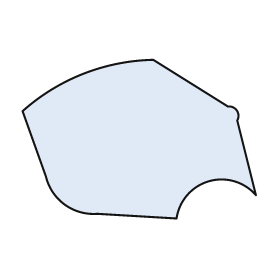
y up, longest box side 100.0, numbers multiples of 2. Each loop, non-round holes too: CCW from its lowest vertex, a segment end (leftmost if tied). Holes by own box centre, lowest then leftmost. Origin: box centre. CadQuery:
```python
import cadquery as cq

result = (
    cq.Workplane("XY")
    .moveTo(16.0, -34.0)
    .threePointArc((30.0, -18.0), (50.0, -24.0))
    .lineTo(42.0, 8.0)
    .threePointArc((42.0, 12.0), (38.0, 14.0))
    .lineTo(6.0, 34.0)
    .threePointArc((-24.0, 28.0), (-50.0, 12.0))
    .lineTo(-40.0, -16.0)
    .threePointArc((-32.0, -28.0), (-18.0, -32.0))
    .close()
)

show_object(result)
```